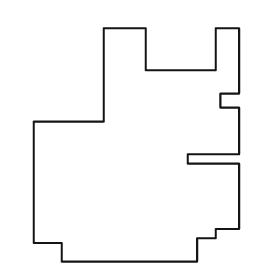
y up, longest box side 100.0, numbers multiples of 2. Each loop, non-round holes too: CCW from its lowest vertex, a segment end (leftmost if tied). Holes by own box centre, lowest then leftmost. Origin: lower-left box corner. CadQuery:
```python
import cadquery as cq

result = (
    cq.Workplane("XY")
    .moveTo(12.0, 0.0)
    .lineTo(70.0, 0.0)
    .lineTo(70.0, 10.0)
    .lineTo(78.0, 10.0)
    .lineTo(78.0, 14.0)
    .lineTo(88.0, 14.0)
    .lineTo(88.0, 42.0)
    .lineTo(66.0, 42.0)
    .lineTo(66.0, 46.0)
    .lineTo(88.0, 46.0)
    .lineTo(88.0, 66.0)
    .lineTo(80.0, 66.0)
    .lineTo(80.0, 72.0)
    .lineTo(88.0, 72.0)
    .lineTo(88.0, 100.0)
    .lineTo(78.0, 100.0)
    .lineTo(78.0, 82.0)
    .lineTo(48.0, 82.0)
    .lineTo(48.0, 100.0)
    .lineTo(30.0, 100.0)
    .lineTo(30.0, 60.0)
    .lineTo(0.0, 60.0)
    .lineTo(0.0, 8.0)
    .lineTo(12.0, 8.0)
    .close()
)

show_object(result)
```